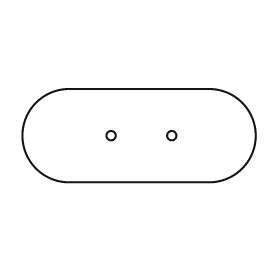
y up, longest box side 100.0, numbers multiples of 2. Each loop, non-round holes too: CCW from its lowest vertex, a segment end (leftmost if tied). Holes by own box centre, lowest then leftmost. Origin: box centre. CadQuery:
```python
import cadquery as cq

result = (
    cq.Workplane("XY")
    .moveTo(-30.0, -20.0)
    .lineTo(30.0, -20.0)
    .threePointArc((50.0, 0.0), (30.0, 20.0))
    .lineTo(-30.0, 20.0)
    .threePointArc((-50.0, 0.0), (-30.0, -20.0))
    .close()
    .moveTo(-12.0, 0.0)
    .circle(2.0)
    .moveTo(14.0, 0.0)
    .circle(2.0)
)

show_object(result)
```